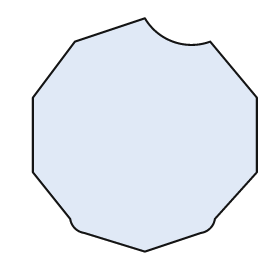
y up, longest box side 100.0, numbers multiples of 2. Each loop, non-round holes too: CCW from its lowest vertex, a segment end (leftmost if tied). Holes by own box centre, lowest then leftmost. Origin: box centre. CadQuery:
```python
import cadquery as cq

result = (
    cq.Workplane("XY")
    .moveTo(0.0, -50.0)
    .lineTo(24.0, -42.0)
    .threePointArc((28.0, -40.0), (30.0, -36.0))
    .lineTo(48.0, -16.0)
    .lineTo(48.0, 16.0)
    .lineTo(28.0, 40.0)
    .threePointArc((12.0, 40.0), (0.0, 50.0))
    .lineTo(-30.0, 40.0)
    .lineTo(-48.0, 16.0)
    .lineTo(-48.0, -16.0)
    .lineTo(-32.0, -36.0)
    .threePointArc((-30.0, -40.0), (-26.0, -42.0))
    .close()
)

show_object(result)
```